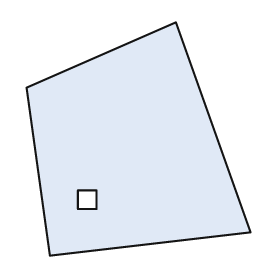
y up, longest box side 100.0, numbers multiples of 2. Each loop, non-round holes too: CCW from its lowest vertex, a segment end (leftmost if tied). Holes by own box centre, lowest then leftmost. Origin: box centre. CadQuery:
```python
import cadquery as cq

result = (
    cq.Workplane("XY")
    .moveTo(-38.0, -50.0)
    .lineTo(48.0, -40.0)
    .lineTo(16.0, 50.0)
    .lineTo(-48.0, 22.0)
    .close()
    .moveTo(-26.0, -30.0)
    .lineTo(-18.0, -30.0)
    .lineTo(-18.0, -22.0)
    .lineTo(-26.0, -22.0)
    .close()
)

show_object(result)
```